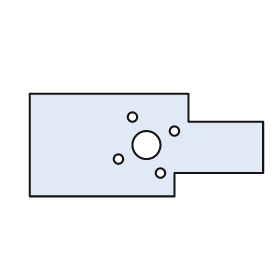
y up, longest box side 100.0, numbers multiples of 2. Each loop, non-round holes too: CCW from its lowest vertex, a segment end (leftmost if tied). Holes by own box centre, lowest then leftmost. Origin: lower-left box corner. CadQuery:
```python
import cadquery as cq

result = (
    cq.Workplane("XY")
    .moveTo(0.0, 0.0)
    .lineTo(62.0, 0.0)
    .lineTo(62.0, 10.0)
    .lineTo(100.0, 10.0)
    .lineTo(100.0, 32.0)
    .lineTo(68.0, 32.0)
    .lineTo(68.0, 44.0)
    .lineTo(0.0, 44.0)
    .close()
    .moveTo(56.0, 10.0)
    .circle(2.0)
    .moveTo(38.0, 16.0)
    .circle(2.0)
    .moveTo(50.0, 22.0)
    .circle(6.0)
    .moveTo(62.0, 28.0)
    .circle(2.0)
    .moveTo(44.0, 34.0)
    .circle(2.0)
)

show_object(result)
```